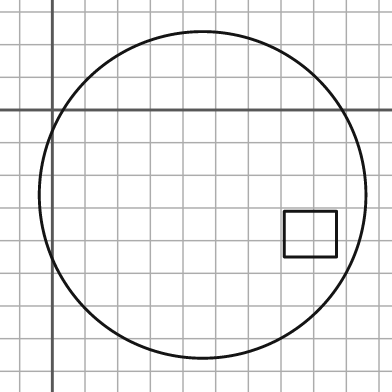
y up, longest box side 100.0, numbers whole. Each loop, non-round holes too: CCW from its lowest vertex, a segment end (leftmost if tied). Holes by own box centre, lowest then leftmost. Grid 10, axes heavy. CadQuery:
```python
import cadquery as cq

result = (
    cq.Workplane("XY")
    .moveTo(46.0, -26.0)
    .circle(50.0)
    .moveTo(71.0, -45.0)
    .lineTo(87.0, -45.0)
    .lineTo(87.0, -31.0)
    .lineTo(71.0, -31.0)
    .close()
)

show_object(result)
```